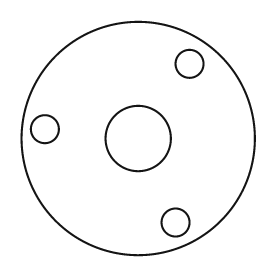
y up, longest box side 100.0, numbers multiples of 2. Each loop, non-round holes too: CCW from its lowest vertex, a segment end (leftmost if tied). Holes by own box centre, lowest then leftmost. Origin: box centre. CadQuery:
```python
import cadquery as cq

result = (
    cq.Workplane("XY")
    .moveTo(0.0, 0.0)
    .circle(50.0)
    .moveTo(16.0, -36.0)
    .circle(6.0)
    .moveTo(0.0, 0.0)
    .circle(14.0)
    .moveTo(-40.0, 4.0)
    .circle(6.0)
    .moveTo(22.0, 32.0)
    .circle(6.0)
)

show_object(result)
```